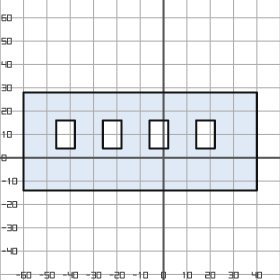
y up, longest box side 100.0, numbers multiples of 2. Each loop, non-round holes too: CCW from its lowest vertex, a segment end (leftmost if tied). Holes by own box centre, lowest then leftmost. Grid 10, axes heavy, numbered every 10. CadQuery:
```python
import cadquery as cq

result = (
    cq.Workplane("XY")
    .moveTo(-60.0, -14.0)
    .lineTo(40.0, -14.0)
    .lineTo(40.0, 28.0)
    .lineTo(-60.0, 28.0)
    .close()
    .moveTo(-46.0, 4.0)
    .lineTo(-38.0, 4.0)
    .lineTo(-38.0, 16.0)
    .lineTo(-46.0, 16.0)
    .close()
    .moveTo(-26.0, 4.0)
    .lineTo(-18.0, 4.0)
    .lineTo(-18.0, 16.0)
    .lineTo(-26.0, 16.0)
    .close()
    .moveTo(-6.0, 4.0)
    .lineTo(2.0, 4.0)
    .lineTo(2.0, 16.0)
    .lineTo(-6.0, 16.0)
    .close()
    .moveTo(14.0, 4.0)
    .lineTo(22.0, 4.0)
    .lineTo(22.0, 16.0)
    .lineTo(14.0, 16.0)
    .close()
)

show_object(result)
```